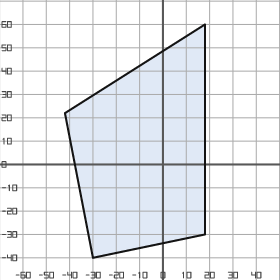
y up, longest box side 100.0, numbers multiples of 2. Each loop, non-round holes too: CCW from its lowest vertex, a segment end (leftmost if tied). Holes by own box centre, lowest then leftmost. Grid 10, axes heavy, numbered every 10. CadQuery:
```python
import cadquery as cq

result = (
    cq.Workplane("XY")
    .moveTo(-30.0, -40.0)
    .lineTo(18.0, -30.0)
    .lineTo(18.0, 60.0)
    .lineTo(-42.0, 22.0)
    .close()
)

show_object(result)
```